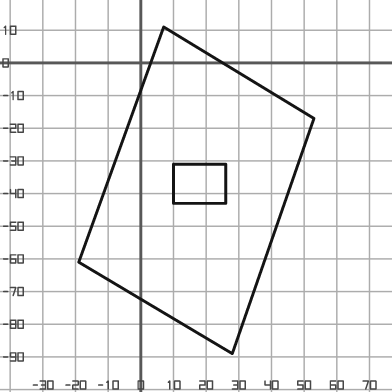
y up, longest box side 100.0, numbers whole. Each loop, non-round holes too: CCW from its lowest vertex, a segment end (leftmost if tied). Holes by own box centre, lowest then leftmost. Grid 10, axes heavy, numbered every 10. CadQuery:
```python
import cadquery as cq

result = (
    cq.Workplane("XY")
    .moveTo(28.0, -89.0)
    .lineTo(53.0, -17.0)
    .lineTo(7.0, 11.0)
    .lineTo(-19.0, -61.0)
    .close()
    .moveTo(10.0, -43.0)
    .lineTo(26.0, -43.0)
    .lineTo(26.0, -31.0)
    .lineTo(10.0, -31.0)
    .close()
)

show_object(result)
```